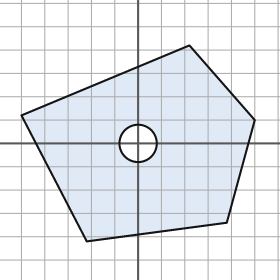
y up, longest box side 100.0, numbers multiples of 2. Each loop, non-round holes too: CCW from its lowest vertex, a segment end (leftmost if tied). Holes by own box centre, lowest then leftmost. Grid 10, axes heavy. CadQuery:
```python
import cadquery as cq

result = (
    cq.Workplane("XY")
    .moveTo(-22.0, -42.0)
    .lineTo(38.0, -34.0)
    .lineTo(50.0, 10.0)
    .lineTo(22.0, 42.0)
    .lineTo(-50.0, 12.0)
    .close()
    .moveTo(0.0, 0.0)
    .circle(8.0)
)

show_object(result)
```